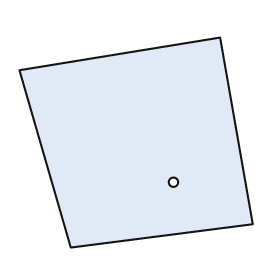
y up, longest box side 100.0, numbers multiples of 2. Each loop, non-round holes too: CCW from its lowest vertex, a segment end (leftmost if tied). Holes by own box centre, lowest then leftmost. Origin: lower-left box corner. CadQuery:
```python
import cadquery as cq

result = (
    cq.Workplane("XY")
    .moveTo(22.0, 0.0)
    .lineTo(100.0, 10.0)
    .lineTo(86.0, 90.0)
    .lineTo(0.0, 76.0)
    .close()
    .moveTo(66.0, 28.0)
    .circle(2.0)
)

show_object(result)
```